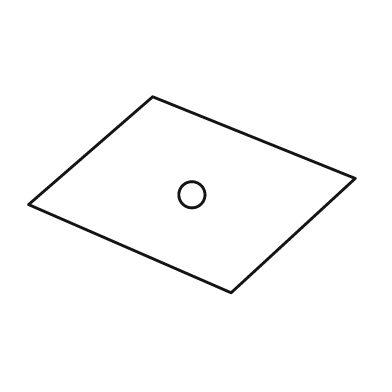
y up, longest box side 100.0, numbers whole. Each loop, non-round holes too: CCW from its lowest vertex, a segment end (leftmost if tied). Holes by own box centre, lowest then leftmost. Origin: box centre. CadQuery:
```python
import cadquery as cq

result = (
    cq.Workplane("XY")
    .moveTo(12.0, -30.0)
    .lineTo(50.0, 5.0)
    .lineTo(-12.0, 30.0)
    .lineTo(-50.0, -3.0)
    .close()
    .moveTo(0.0, 0.0)
    .circle(4.0)
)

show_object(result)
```